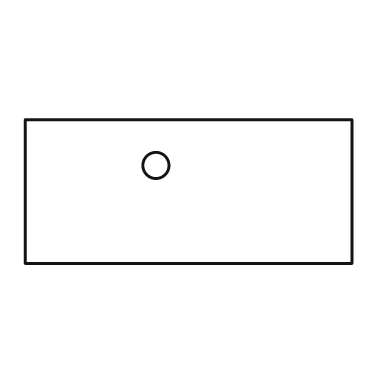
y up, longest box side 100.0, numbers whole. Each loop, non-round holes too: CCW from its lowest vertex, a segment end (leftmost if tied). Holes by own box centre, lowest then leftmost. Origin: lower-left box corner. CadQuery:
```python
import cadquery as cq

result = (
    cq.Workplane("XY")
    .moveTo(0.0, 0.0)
    .lineTo(100.0, 0.0)
    .lineTo(100.0, 44.0)
    .lineTo(0.0, 44.0)
    .close()
    .moveTo(40.0, 30.0)
    .circle(4.0)
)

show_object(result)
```